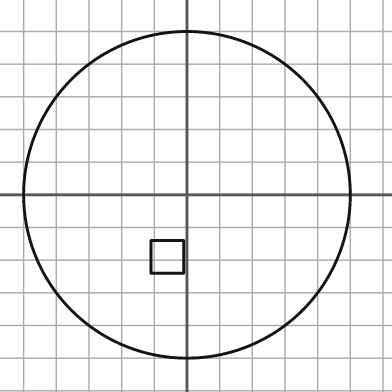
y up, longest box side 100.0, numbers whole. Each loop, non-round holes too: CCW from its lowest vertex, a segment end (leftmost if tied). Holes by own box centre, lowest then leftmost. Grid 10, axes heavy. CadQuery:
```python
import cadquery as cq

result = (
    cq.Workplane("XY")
    .moveTo(0.0, 0.0)
    .circle(50.0)
    .moveTo(-11.0, -24.0)
    .lineTo(-1.0, -24.0)
    .lineTo(-1.0, -14.0)
    .lineTo(-11.0, -14.0)
    .close()
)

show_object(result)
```